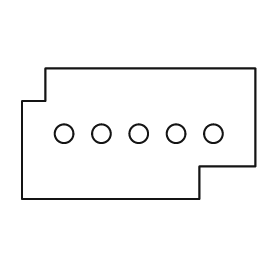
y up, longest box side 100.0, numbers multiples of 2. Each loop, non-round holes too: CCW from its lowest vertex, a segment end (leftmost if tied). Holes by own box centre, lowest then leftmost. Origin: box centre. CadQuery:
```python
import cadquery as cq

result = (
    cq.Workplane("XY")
    .moveTo(-50.0, -28.0)
    .lineTo(26.0, -28.0)
    .lineTo(26.0, -14.0)
    .lineTo(50.0, -14.0)
    .lineTo(50.0, 28.0)
    .lineTo(-40.0, 28.0)
    .lineTo(-40.0, 14.0)
    .lineTo(-50.0, 14.0)
    .close()
    .moveTo(-32.0, 0.0)
    .circle(4.0)
    .moveTo(-16.0, 0.0)
    .circle(4.0)
    .moveTo(0.0, 0.0)
    .circle(4.0)
    .moveTo(16.0, 0.0)
    .circle(4.0)
    .moveTo(32.0, 0.0)
    .circle(4.0)
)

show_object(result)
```